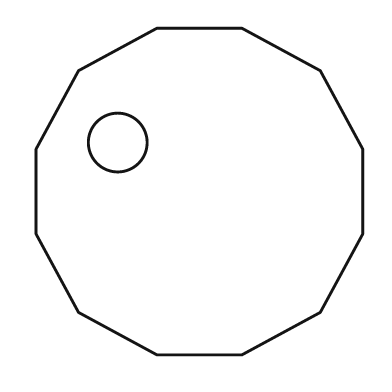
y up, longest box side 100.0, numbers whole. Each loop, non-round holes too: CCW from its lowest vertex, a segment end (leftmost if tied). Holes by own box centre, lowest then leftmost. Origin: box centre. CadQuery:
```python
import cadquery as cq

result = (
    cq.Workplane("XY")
    .moveTo(-13.0, -50.0)
    .lineTo(13.0, -50.0)
    .lineTo(37.0, -37.0)
    .lineTo(50.0, -13.0)
    .lineTo(50.0, 13.0)
    .lineTo(37.0, 37.0)
    .lineTo(13.0, 50.0)
    .lineTo(-13.0, 50.0)
    .lineTo(-37.0, 37.0)
    .lineTo(-50.0, 13.0)
    .lineTo(-50.0, -13.0)
    .lineTo(-37.0, -37.0)
    .close()
    .moveTo(-25.0, 15.0)
    .circle(9.0)
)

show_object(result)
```